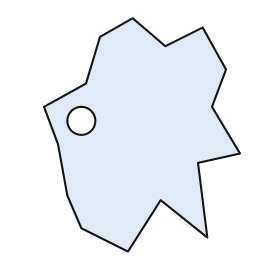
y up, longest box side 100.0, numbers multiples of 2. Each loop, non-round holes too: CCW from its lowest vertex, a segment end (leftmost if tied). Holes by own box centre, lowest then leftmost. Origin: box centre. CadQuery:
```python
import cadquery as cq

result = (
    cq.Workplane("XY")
    .moveTo(-6.0, -50.0)
    .lineTo(8.0, -28.0)
    .lineTo(28.0, -44.0)
    .lineTo(24.0, -12.0)
    .lineTo(42.0, -8.0)
    .lineTo(30.0, 12.0)
    .lineTo(36.0, 28.0)
    .lineTo(26.0, 46.0)
    .lineTo(10.0, 38.0)
    .lineTo(-4.0, 50.0)
    .lineTo(-18.0, 42.0)
    .lineTo(-24.0, 22.0)
    .lineTo(-42.0, 12.0)
    .lineTo(-36.0, -4.0)
    .lineTo(-32.0, -26.0)
    .lineTo(-26.0, -40.0)
    .close()
    .moveTo(-26.0, 6.0)
    .circle(6.0)
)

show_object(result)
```